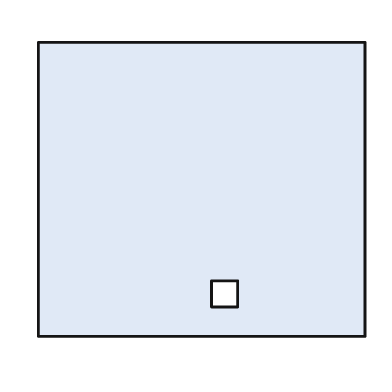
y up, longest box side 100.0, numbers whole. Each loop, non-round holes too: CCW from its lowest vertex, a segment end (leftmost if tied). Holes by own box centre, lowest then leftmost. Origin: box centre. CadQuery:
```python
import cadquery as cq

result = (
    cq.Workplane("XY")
    .moveTo(-50.0, -45.0)
    .lineTo(50.0, -45.0)
    .lineTo(50.0, 45.0)
    .lineTo(-50.0, 45.0)
    .close()
    .moveTo(3.0, -36.0)
    .lineTo(11.0, -36.0)
    .lineTo(11.0, -28.0)
    .lineTo(3.0, -28.0)
    .close()
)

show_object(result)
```